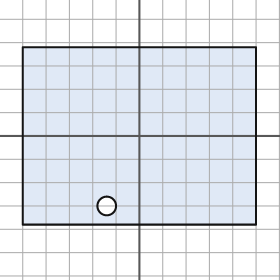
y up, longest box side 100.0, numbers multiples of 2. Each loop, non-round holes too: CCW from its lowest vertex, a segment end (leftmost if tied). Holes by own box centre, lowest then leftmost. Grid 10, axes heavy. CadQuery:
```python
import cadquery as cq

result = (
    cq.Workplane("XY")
    .moveTo(-50.0, -38.0)
    .lineTo(50.0, -38.0)
    .lineTo(50.0, 38.0)
    .lineTo(-50.0, 38.0)
    .close()
    .moveTo(-14.0, -30.0)
    .circle(4.0)
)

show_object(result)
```